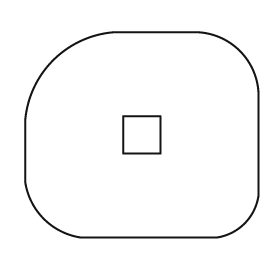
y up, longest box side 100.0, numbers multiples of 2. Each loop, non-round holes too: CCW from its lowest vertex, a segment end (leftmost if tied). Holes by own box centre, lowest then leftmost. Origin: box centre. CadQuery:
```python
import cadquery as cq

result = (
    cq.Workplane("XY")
    .moveTo(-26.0, -44.0)
    .lineTo(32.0, -44.0)
    .threePointArc((44.0, -38.0), (50.0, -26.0))
    .lineTo(50.0, 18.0)
    .threePointArc((42.0, 36.0), (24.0, 44.0))
    .lineTo(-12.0, 44.0)
    .threePointArc((-38.0, 32.0), (-50.0, 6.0))
    .lineTo(-50.0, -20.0)
    .threePointArc((-42.0, -36.0), (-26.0, -44.0))
    .close()
    .moveTo(-8.0, -8.0)
    .lineTo(8.0, -8.0)
    .lineTo(8.0, 8.0)
    .lineTo(-8.0, 8.0)
    .close()
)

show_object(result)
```